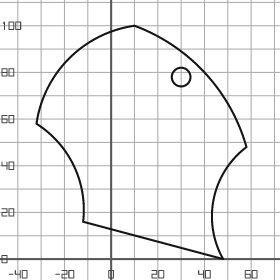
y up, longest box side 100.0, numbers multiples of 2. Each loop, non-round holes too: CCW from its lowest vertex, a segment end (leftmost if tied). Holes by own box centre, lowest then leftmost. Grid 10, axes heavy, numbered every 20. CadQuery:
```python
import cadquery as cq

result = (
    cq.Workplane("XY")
    .moveTo(48.0, 0.0)
    .threePointArc((44.0, 26.0), (58.0, 48.0))
    .threePointArc((40.0, 80.0), (10.0, 100.0))
    .threePointArc((-18.0, 86.0), (-32.0, 58.0))
    .threePointArc((-16.0, 40.0), (-12.0, 16.0))
    .close()
    .moveTo(30.0, 78.0)
    .circle(4.0)
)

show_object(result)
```